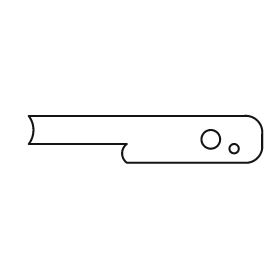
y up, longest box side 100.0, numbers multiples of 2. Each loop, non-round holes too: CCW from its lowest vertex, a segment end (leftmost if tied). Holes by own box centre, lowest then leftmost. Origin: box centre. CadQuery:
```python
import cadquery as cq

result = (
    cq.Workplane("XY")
    .moveTo(-8.0, -10.0)
    .lineTo(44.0, -10.0)
    .threePointArc((48.0, -8.0), (50.0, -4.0))
    .lineTo(50.0, 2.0)
    .threePointArc((48.0, 8.0), (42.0, 10.0))
    .lineTo(-50.0, 10.0)
    .threePointArc((-48.0, 4.0), (-50.0, -2.0))
    .lineTo(-8.0, -2.0)
    .threePointArc((-10.0, -6.0), (-8.0, -10.0))
    .close()
    .moveTo(38.0, -4.0)
    .circle(2.0)
    .moveTo(28.0, 0.0)
    .circle(4.0)
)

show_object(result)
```